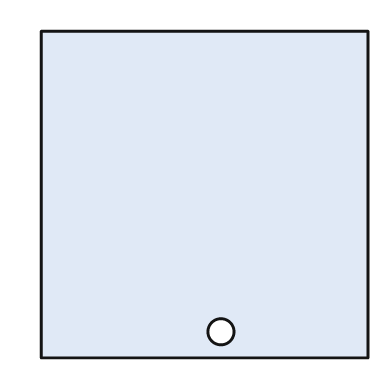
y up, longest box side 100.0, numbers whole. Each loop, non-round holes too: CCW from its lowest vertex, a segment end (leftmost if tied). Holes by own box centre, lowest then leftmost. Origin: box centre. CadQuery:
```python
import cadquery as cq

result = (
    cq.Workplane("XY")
    .moveTo(-50.0, -50.0)
    .lineTo(50.0, -50.0)
    .lineTo(50.0, 50.0)
    .lineTo(-50.0, 50.0)
    .close()
    .moveTo(5.0, -42.0)
    .circle(4.0)
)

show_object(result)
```